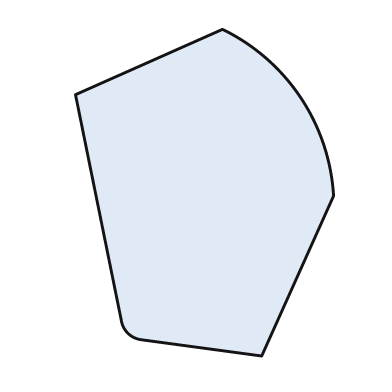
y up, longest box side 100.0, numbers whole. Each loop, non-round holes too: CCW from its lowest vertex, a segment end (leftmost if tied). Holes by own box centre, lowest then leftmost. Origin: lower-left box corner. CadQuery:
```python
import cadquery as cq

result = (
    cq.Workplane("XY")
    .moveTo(57.0, 0.0)
    .lineTo(79.0, 49.0)
    .threePointArc((69.0, 79.0), (45.0, 100.0))
    .lineTo(0.0, 80.0)
    .lineTo(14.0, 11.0)
    .threePointArc((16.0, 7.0), (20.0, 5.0))
    .close()
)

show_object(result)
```